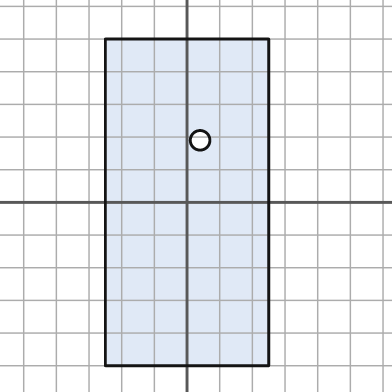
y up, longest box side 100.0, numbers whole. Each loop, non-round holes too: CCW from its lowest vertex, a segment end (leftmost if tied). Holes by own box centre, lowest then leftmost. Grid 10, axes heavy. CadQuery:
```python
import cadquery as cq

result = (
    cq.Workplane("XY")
    .moveTo(-25.0, -50.0)
    .lineTo(25.0, -50.0)
    .lineTo(25.0, 50.0)
    .lineTo(-25.0, 50.0)
    .close()
    .moveTo(4.0, 19.0)
    .circle(3.0)
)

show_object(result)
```